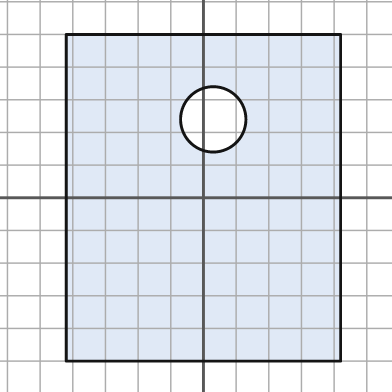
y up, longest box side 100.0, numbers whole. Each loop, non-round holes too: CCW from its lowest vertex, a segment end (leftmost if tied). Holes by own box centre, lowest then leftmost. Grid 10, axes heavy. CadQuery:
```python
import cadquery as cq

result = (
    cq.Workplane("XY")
    .moveTo(-42.0, -50.0)
    .lineTo(42.0, -50.0)
    .lineTo(42.0, 50.0)
    .lineTo(-42.0, 50.0)
    .close()
    .moveTo(3.0, 24.0)
    .circle(10.0)
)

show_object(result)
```